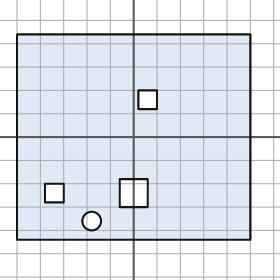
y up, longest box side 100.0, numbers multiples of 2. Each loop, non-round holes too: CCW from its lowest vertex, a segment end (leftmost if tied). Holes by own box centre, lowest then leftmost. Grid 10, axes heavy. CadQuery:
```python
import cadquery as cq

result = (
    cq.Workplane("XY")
    .moveTo(-50.0, -44.0)
    .lineTo(50.0, -44.0)
    .lineTo(50.0, 44.0)
    .lineTo(-50.0, 44.0)
    .close()
    .moveTo(-18.0, -36.0)
    .circle(4.0)
    .moveTo(-38.0, -28.0)
    .lineTo(-30.0, -28.0)
    .lineTo(-30.0, -20.0)
    .lineTo(-38.0, -20.0)
    .close()
    .moveTo(-6.0, -30.0)
    .lineTo(6.0, -30.0)
    .lineTo(6.0, -18.0)
    .lineTo(-6.0, -18.0)
    .close()
    .moveTo(2.0, 12.0)
    .lineTo(10.0, 12.0)
    .lineTo(10.0, 20.0)
    .lineTo(2.0, 20.0)
    .close()
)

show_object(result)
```